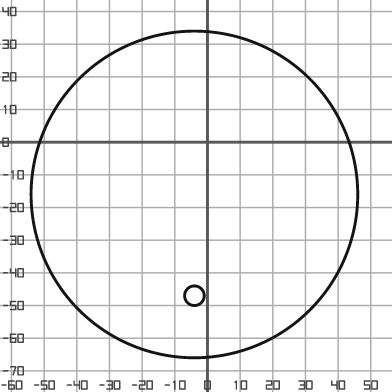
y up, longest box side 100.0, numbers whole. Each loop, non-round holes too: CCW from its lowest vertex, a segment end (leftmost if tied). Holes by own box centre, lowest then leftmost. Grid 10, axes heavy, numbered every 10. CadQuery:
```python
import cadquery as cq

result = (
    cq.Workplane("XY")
    .moveTo(-4.0, -16.0)
    .circle(50.0)
    .moveTo(-4.0, -47.0)
    .circle(3.0)
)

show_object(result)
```